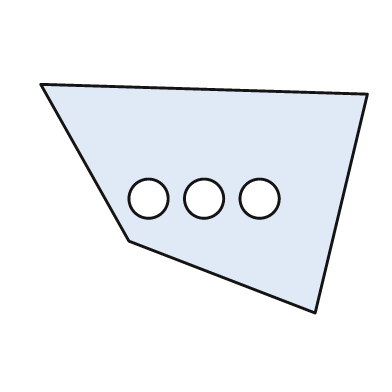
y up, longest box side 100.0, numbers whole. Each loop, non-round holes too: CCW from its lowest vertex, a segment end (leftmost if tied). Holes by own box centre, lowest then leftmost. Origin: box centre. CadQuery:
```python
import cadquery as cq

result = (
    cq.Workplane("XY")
    .moveTo(34.0, -35.0)
    .lineTo(50.0, 32.0)
    .lineTo(-50.0, 35.0)
    .lineTo(-23.0, -13.0)
    .close()
    .moveTo(-17.0, 0.0)
    .circle(6.0)
    .moveTo(0.0, 0.0)
    .circle(6.0)
    .moveTo(17.0, 0.0)
    .circle(6.0)
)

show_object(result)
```